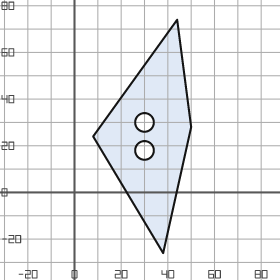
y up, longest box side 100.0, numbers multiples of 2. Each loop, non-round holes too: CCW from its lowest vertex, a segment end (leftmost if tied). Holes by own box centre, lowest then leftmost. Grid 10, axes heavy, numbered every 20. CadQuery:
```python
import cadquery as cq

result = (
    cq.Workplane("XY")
    .moveTo(38.0, -26.0)
    .lineTo(50.0, 28.0)
    .lineTo(44.0, 74.0)
    .lineTo(8.0, 24.0)
    .close()
    .moveTo(30.0, 18.0)
    .circle(4.0)
    .moveTo(30.0, 30.0)
    .circle(4.0)
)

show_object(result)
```